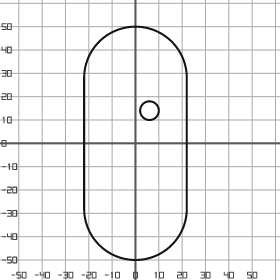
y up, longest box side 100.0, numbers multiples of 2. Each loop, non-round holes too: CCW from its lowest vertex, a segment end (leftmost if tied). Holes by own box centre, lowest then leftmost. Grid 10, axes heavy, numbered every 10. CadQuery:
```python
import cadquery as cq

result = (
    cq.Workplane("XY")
    .moveTo(-22.0, -28.0)
    .threePointArc((0.0, -50.0), (22.0, -28.0))
    .lineTo(22.0, 28.0)
    .threePointArc((0.0, 50.0), (-22.0, 28.0))
    .close()
    .moveTo(6.0, 14.0)
    .circle(4.0)
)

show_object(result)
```